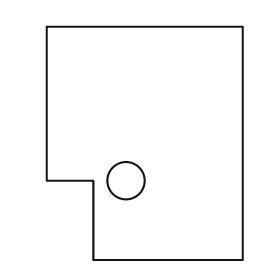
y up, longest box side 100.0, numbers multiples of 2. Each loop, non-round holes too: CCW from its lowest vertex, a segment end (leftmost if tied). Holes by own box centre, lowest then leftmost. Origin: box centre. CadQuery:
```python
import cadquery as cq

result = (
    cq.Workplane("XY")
    .moveTo(-22.0, -50.0)
    .lineTo(42.0, -50.0)
    .lineTo(42.0, 50.0)
    .lineTo(-42.0, 50.0)
    .lineTo(-42.0, -16.0)
    .lineTo(-22.0, -16.0)
    .close()
    .moveTo(-8.0, -16.0)
    .circle(8.0)
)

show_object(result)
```